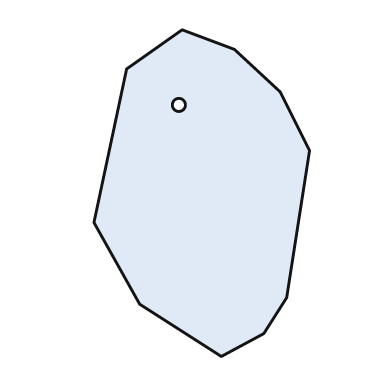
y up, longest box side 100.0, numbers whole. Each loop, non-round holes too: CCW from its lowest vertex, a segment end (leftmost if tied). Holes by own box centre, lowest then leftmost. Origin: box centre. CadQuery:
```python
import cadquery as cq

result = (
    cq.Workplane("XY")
    .moveTo(6.0, -50.0)
    .lineTo(19.0, -43.0)
    .lineTo(26.0, -32.0)
    .lineTo(33.0, 13.0)
    .lineTo(24.0, 31.0)
    .lineTo(10.0, 44.0)
    .lineTo(-6.0, 50.0)
    .lineTo(-23.0, 38.0)
    .lineTo(-33.0, -9.0)
    .lineTo(-19.0, -34.0)
    .close()
    .moveTo(-7.0, 27.0)
    .circle(2.0)
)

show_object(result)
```